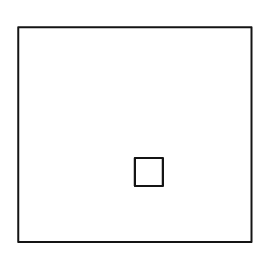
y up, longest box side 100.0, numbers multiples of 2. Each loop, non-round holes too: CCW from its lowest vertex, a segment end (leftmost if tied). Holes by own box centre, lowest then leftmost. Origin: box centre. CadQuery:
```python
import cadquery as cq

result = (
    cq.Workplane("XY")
    .moveTo(-50.0, -46.0)
    .lineTo(50.0, -46.0)
    .lineTo(50.0, 46.0)
    .lineTo(-50.0, 46.0)
    .close()
    .moveTo(0.0, -22.0)
    .lineTo(12.0, -22.0)
    .lineTo(12.0, -10.0)
    .lineTo(0.0, -10.0)
    .close()
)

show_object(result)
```